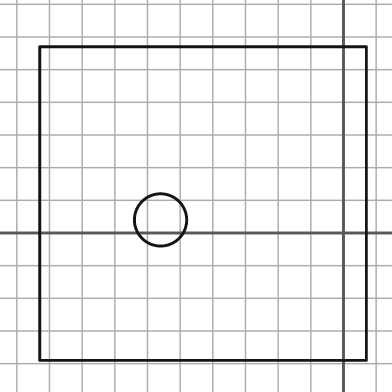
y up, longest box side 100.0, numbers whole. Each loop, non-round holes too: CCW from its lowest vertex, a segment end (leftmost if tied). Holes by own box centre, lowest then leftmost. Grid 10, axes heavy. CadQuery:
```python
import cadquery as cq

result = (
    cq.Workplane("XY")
    .moveTo(-93.0, -39.0)
    .lineTo(7.0, -39.0)
    .lineTo(7.0, 57.0)
    .lineTo(-93.0, 57.0)
    .close()
    .moveTo(-56.0, 4.0)
    .circle(8.0)
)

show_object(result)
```